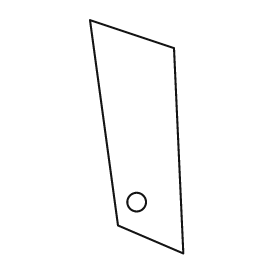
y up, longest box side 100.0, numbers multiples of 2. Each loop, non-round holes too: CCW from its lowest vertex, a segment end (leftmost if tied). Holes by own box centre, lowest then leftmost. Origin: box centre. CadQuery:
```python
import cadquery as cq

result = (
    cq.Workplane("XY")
    .moveTo(20.0, -50.0)
    .lineTo(16.0, 38.0)
    .lineTo(-20.0, 50.0)
    .lineTo(-8.0, -38.0)
    .close()
    .moveTo(0.0, -28.0)
    .circle(4.0)
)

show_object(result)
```